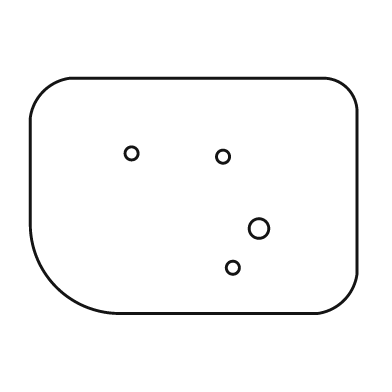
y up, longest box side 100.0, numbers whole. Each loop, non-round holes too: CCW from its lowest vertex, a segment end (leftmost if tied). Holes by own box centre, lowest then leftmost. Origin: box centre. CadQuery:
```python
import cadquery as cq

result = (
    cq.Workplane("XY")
    .moveTo(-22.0, -36.0)
    .lineTo(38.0, -36.0)
    .threePointArc((46.0, -32.0), (50.0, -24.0))
    .lineTo(50.0, 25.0)
    .threePointArc((47.0, 33.0), (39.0, 36.0))
    .lineTo(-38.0, 36.0)
    .threePointArc((-46.0, 32.0), (-50.0, 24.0))
    .lineTo(-50.0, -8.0)
    .threePointArc((-42.0, -28.0), (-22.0, -36.0))
    .close()
    .moveTo(12.0, -22.0)
    .circle(2.0)
    .moveTo(20.0, -10.0)
    .circle(3.0)
    .moveTo(9.0, 12.0)
    .circle(2.0)
    .moveTo(-19.0, 13.0)
    .circle(2.0)
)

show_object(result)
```